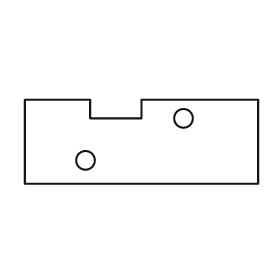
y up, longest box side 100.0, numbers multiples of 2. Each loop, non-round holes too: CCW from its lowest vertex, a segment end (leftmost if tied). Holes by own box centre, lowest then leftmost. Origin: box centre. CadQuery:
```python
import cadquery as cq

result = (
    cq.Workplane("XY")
    .moveTo(-50.0, -18.0)
    .lineTo(50.0, -18.0)
    .lineTo(50.0, 18.0)
    .lineTo(0.0, 18.0)
    .lineTo(0.0, 10.0)
    .lineTo(-22.0, 10.0)
    .lineTo(-22.0, 18.0)
    .lineTo(-50.0, 18.0)
    .close()
    .moveTo(-24.0, -8.0)
    .circle(4.0)
    .moveTo(18.0, 10.0)
    .circle(4.0)
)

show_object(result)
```